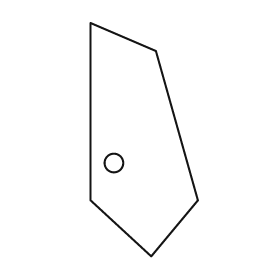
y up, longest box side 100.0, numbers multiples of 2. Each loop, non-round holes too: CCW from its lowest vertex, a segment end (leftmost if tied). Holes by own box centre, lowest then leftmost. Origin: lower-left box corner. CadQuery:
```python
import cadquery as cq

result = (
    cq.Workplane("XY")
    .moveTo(26.0, 0.0)
    .lineTo(46.0, 24.0)
    .lineTo(28.0, 88.0)
    .lineTo(0.0, 100.0)
    .lineTo(0.0, 24.0)
    .close()
    .moveTo(10.0, 40.0)
    .circle(4.0)
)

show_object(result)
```